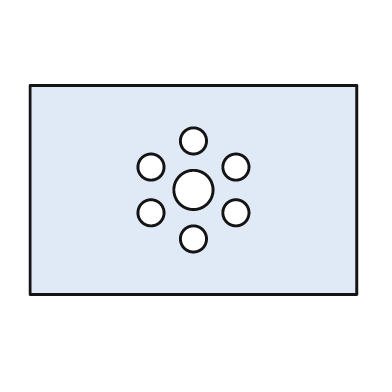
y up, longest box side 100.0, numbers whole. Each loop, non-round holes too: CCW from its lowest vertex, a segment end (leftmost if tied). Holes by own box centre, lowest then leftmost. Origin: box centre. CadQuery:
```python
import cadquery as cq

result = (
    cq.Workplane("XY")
    .moveTo(-50.0, -32.0)
    .lineTo(50.0, -32.0)
    .lineTo(50.0, 32.0)
    .lineTo(-50.0, 32.0)
    .close()
    .moveTo(0.0, -15.0)
    .circle(4.0)
    .moveTo(-13.0, -7.0)
    .circle(4.0)
    .moveTo(13.0, -7.0)
    .circle(4.0)
    .moveTo(0.0, 0.0)
    .circle(6.0)
    .moveTo(-13.0, 7.0)
    .circle(4.0)
    .moveTo(13.0, 7.0)
    .circle(4.0)
    .moveTo(0.0, 15.0)
    .circle(4.0)
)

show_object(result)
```